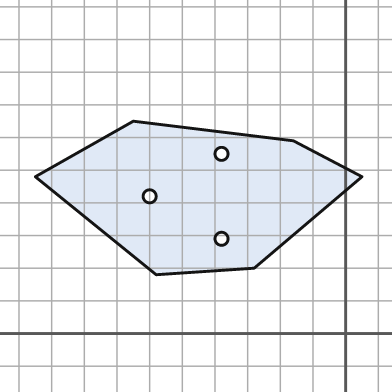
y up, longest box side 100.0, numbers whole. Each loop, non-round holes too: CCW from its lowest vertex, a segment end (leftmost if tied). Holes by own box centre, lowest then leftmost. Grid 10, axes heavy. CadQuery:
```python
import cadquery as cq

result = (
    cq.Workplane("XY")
    .moveTo(-58.0, 18.0)
    .lineTo(-28.0, 20.0)
    .lineTo(5.0, 48.0)
    .lineTo(-16.0, 59.0)
    .lineTo(-65.0, 65.0)
    .lineTo(-95.0, 48.0)
    .close()
    .moveTo(-38.0, 29.0)
    .circle(2.0)
    .moveTo(-60.0, 42.0)
    .circle(2.0)
    .moveTo(-38.0, 55.0)
    .circle(2.0)
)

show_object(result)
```